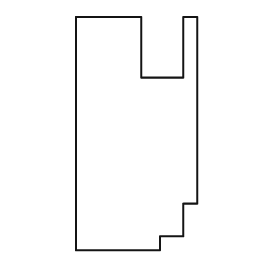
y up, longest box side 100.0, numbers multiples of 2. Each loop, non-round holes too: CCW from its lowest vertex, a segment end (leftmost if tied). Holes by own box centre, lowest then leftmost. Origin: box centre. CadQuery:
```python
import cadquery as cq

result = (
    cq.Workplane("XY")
    .moveTo(-26.0, -50.0)
    .lineTo(10.0, -50.0)
    .lineTo(10.0, -44.0)
    .lineTo(20.0, -44.0)
    .lineTo(20.0, -30.0)
    .lineTo(26.0, -30.0)
    .lineTo(26.0, 50.0)
    .lineTo(20.0, 50.0)
    .lineTo(20.0, 24.0)
    .lineTo(2.0, 24.0)
    .lineTo(2.0, 50.0)
    .lineTo(-26.0, 50.0)
    .close()
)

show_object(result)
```